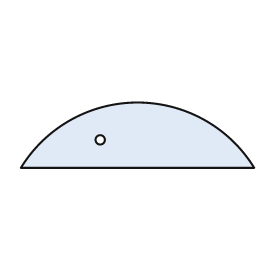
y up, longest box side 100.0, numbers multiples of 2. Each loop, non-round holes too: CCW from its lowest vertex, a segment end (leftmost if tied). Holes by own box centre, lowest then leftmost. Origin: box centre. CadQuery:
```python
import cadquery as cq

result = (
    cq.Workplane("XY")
    .moveTo(-50.0, -14.0)
    .lineTo(50.0, -14.0)
    .threePointArc((0.0, 14.0), (-50.0, -14.0))
    .close()
    .moveTo(-16.0, -2.0)
    .circle(2.0)
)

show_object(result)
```